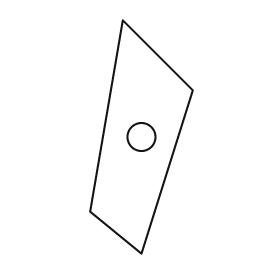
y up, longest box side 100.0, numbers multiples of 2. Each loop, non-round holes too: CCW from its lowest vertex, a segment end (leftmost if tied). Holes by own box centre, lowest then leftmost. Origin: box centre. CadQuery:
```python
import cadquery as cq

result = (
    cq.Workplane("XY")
    .moveTo(0.0, -50.0)
    .lineTo(22.0, 20.0)
    .lineTo(-8.0, 50.0)
    .lineTo(-22.0, -32.0)
    .close()
    .moveTo(0.0, 0.0)
    .circle(6.0)
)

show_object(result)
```